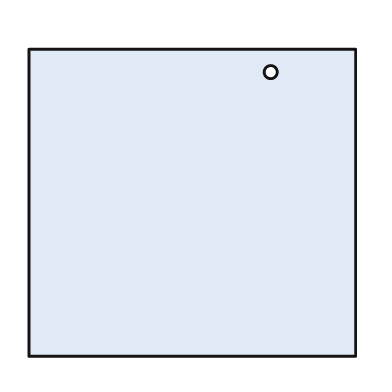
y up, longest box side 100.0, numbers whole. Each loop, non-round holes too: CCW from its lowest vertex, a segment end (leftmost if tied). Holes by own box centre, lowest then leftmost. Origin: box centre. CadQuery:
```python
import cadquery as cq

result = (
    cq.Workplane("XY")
    .moveTo(-50.0, -47.0)
    .lineTo(50.0, -47.0)
    .lineTo(50.0, 47.0)
    .lineTo(-50.0, 47.0)
    .close()
    .moveTo(24.0, 40.0)
    .circle(2.0)
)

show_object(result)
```